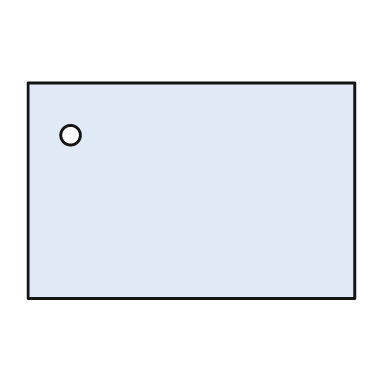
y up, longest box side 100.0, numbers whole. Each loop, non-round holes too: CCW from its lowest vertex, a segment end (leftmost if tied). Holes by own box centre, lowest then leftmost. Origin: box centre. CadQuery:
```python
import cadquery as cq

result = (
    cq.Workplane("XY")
    .moveTo(-50.0, -33.0)
    .lineTo(50.0, -33.0)
    .lineTo(50.0, 33.0)
    .lineTo(-50.0, 33.0)
    .close()
    .moveTo(-37.0, 17.0)
    .circle(3.0)
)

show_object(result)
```